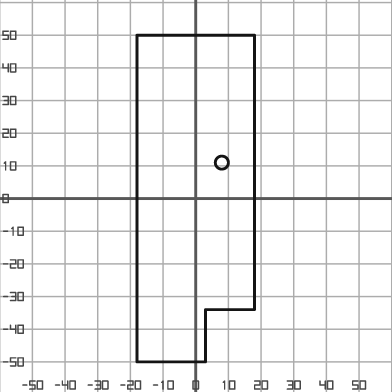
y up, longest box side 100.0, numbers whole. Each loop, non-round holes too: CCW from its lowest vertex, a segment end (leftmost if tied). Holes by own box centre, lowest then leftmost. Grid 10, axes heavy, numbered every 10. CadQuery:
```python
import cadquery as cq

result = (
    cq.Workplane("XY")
    .moveTo(-18.0, -50.0)
    .lineTo(3.0, -50.0)
    .lineTo(3.0, -34.0)
    .lineTo(18.0, -34.0)
    .lineTo(18.0, 50.0)
    .lineTo(-18.0, 50.0)
    .close()
    .moveTo(8.0, 11.0)
    .circle(2.0)
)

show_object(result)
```